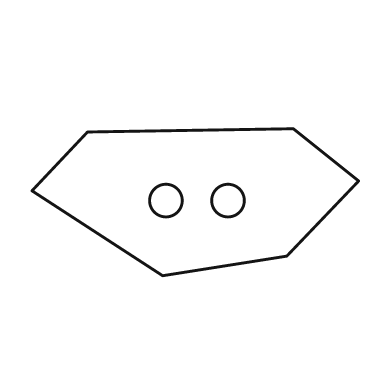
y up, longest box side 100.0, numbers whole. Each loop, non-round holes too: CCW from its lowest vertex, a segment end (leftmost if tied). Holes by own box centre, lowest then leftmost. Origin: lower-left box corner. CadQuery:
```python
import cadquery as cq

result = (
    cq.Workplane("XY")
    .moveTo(40.0, 0.0)
    .lineTo(78.0, 6.0)
    .lineTo(100.0, 29.0)
    .lineTo(80.0, 45.0)
    .lineTo(17.0, 44.0)
    .lineTo(0.0, 26.0)
    .close()
    .moveTo(41.0, 23.0)
    .circle(5.0)
    .moveTo(60.0, 23.0)
    .circle(5.0)
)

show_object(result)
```